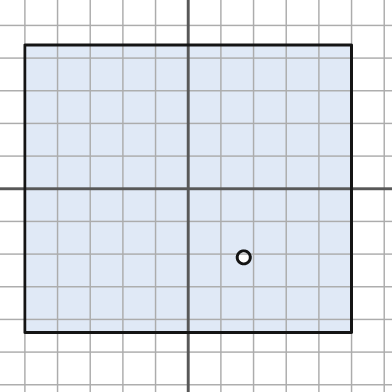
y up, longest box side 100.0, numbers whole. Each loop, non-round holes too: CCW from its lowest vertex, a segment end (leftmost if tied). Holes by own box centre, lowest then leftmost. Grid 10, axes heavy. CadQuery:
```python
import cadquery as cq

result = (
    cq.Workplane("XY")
    .moveTo(-50.0, -44.0)
    .lineTo(50.0, -44.0)
    .lineTo(50.0, 44.0)
    .lineTo(-50.0, 44.0)
    .close()
    .moveTo(17.0, -21.0)
    .circle(2.0)
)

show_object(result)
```